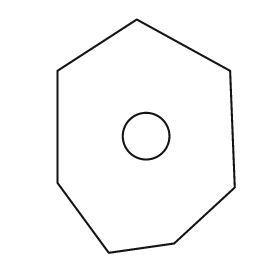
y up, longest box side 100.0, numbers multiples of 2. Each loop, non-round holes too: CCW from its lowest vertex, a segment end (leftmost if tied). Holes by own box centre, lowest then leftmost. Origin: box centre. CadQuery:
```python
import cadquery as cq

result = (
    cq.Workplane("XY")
    .moveTo(-16.0, -50.0)
    .lineTo(12.0, -46.0)
    .lineTo(38.0, -22.0)
    .lineTo(36.0, 28.0)
    .lineTo(-4.0, 50.0)
    .lineTo(-38.0, 28.0)
    .lineTo(-38.0, -20.0)
    .close()
    .moveTo(0.0, 0.0)
    .circle(10.0)
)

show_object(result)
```